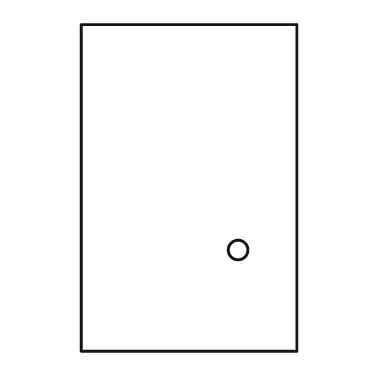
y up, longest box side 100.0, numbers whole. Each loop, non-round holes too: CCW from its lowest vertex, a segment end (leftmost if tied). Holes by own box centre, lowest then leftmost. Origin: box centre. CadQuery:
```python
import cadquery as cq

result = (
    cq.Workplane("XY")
    .moveTo(-33.0, -50.0)
    .lineTo(33.0, -50.0)
    .lineTo(33.0, 50.0)
    .lineTo(-33.0, 50.0)
    .close()
    .moveTo(15.0, -19.0)
    .circle(3.0)
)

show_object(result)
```